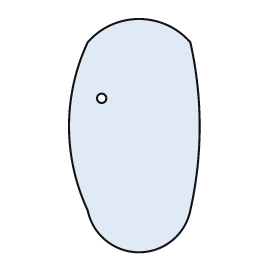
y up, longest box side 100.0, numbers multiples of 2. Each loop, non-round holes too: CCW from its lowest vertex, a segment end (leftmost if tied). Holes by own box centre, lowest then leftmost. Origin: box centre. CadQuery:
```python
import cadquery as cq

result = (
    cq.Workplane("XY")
    .moveTo(-20.0, -32.0)
    .threePointArc((2.0, -50.0), (24.0, -32.0))
    .threePointArc((28.0, 4.0), (24.0, 40.0))
    .threePointArc((2.0, 50.0), (-20.0, 40.0))
    .threePointArc((-28.0, 4.0), (-20.0, -32.0))
    .close()
    .moveTo(-14.0, 16.0)
    .circle(2.0)
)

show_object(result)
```